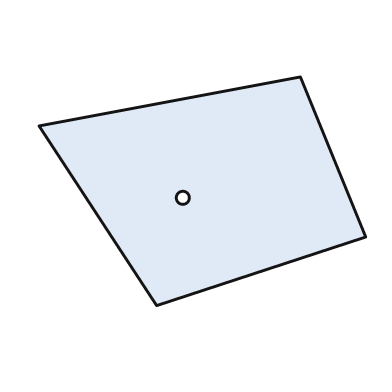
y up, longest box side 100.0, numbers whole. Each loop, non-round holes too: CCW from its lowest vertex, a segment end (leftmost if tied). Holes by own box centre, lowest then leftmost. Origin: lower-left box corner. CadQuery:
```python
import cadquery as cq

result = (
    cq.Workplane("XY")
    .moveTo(36.0, 0.0)
    .lineTo(100.0, 21.0)
    .lineTo(80.0, 70.0)
    .lineTo(0.0, 55.0)
    .close()
    .moveTo(44.0, 33.0)
    .circle(2.0)
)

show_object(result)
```